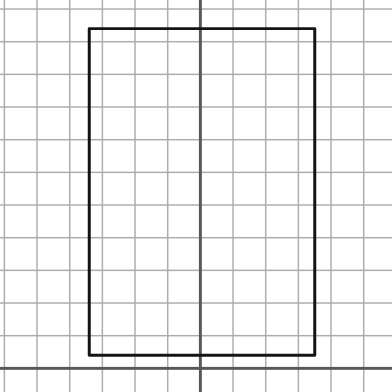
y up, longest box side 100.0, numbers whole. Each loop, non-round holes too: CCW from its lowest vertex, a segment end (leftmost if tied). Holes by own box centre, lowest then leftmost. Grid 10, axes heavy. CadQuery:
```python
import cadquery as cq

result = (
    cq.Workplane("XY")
    .moveTo(-34.0, 4.0)
    .lineTo(35.0, 4.0)
    .lineTo(35.0, 104.0)
    .lineTo(-34.0, 104.0)
    .close()
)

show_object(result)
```